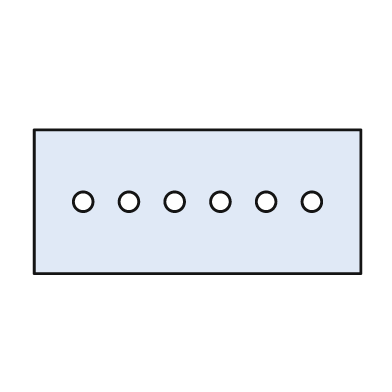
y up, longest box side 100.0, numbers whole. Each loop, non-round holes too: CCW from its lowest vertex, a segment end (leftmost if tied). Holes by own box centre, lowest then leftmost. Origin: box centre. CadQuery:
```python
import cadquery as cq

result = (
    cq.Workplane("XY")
    .moveTo(-50.0, -22.0)
    .lineTo(50.0, -22.0)
    .lineTo(50.0, 22.0)
    .lineTo(-50.0, 22.0)
    .close()
    .moveTo(-35.0, 0.0)
    .circle(3.0)
    .moveTo(-21.0, 0.0)
    .circle(3.0)
    .moveTo(-7.0, 0.0)
    .circle(3.0)
    .moveTo(7.0, 0.0)
    .circle(3.0)
    .moveTo(21.0, 0.0)
    .circle(3.0)
    .moveTo(35.0, 0.0)
    .circle(3.0)
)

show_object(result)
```